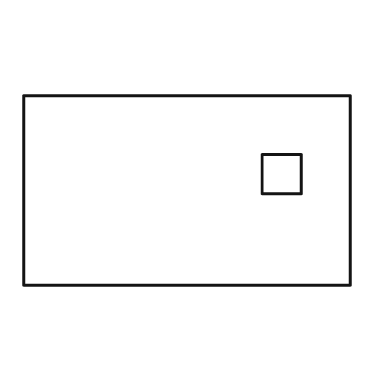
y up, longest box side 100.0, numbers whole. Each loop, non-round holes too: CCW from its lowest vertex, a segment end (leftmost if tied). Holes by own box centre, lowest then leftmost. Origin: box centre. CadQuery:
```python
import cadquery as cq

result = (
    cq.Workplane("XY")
    .moveTo(-50.0, -29.0)
    .lineTo(50.0, -29.0)
    .lineTo(50.0, 29.0)
    .lineTo(-50.0, 29.0)
    .close()
    .moveTo(23.0, -1.0)
    .lineTo(35.0, -1.0)
    .lineTo(35.0, 11.0)
    .lineTo(23.0, 11.0)
    .close()
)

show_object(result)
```